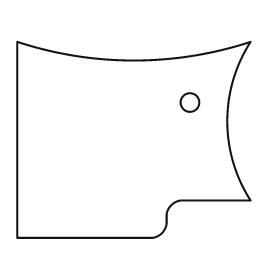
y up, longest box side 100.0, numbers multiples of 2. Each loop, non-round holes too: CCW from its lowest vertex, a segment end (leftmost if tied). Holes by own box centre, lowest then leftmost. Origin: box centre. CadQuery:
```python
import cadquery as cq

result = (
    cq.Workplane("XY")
    .moveTo(-50.0, -42.0)
    .lineTo(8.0, -42.0)
    .threePointArc((12.0, -40.0), (14.0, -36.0))
    .lineTo(14.0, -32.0)
    .threePointArc((16.0, -28.0), (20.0, -26.0))
    .lineTo(50.0, -26.0)
    .threePointArc((40.0, 8.0), (50.0, 42.0))
    .threePointArc((0.0, 34.0), (-50.0, 42.0))
    .close()
    .moveTo(24.0, 16.0)
    .circle(4.0)
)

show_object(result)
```